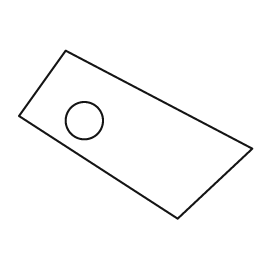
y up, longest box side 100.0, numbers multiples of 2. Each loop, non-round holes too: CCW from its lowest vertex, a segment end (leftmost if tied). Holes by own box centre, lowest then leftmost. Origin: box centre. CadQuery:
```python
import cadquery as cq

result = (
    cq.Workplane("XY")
    .moveTo(18.0, -36.0)
    .lineTo(50.0, -6.0)
    .lineTo(-30.0, 36.0)
    .lineTo(-50.0, 8.0)
    .close()
    .moveTo(-22.0, 6.0)
    .circle(8.0)
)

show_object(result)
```